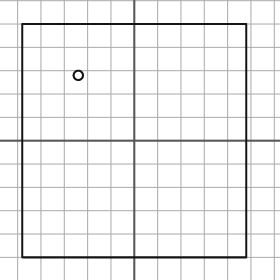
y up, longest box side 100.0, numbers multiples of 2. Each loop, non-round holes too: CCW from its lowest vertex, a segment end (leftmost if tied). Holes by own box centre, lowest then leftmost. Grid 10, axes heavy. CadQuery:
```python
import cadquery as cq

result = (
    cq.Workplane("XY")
    .moveTo(-48.0, -50.0)
    .lineTo(48.0, -50.0)
    .lineTo(48.0, 50.0)
    .lineTo(-48.0, 50.0)
    .close()
    .moveTo(-24.0, 28.0)
    .circle(2.0)
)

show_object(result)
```